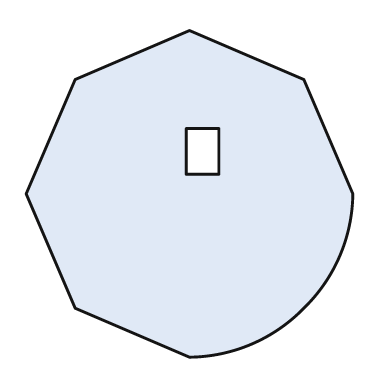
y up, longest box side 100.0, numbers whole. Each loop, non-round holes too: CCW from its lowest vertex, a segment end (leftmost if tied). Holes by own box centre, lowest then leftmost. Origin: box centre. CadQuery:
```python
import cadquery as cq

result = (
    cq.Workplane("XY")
    .moveTo(0.0, -50.0)
    .threePointArc((19.0, -46.0), (35.0, -35.0))
    .threePointArc((46.0, -19.0), (50.0, 0.0))
    .lineTo(35.0, 35.0)
    .lineTo(0.0, 50.0)
    .lineTo(-35.0, 35.0)
    .lineTo(-50.0, 0.0)
    .lineTo(-35.0, -35.0)
    .close()
    .moveTo(-1.0, 6.0)
    .lineTo(9.0, 6.0)
    .lineTo(9.0, 20.0)
    .lineTo(-1.0, 20.0)
    .close()
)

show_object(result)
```